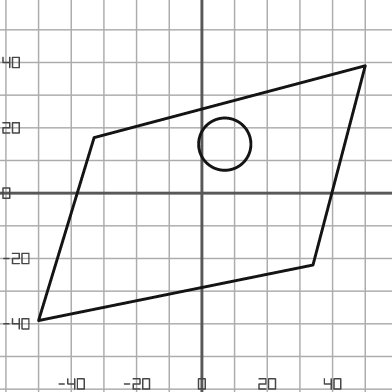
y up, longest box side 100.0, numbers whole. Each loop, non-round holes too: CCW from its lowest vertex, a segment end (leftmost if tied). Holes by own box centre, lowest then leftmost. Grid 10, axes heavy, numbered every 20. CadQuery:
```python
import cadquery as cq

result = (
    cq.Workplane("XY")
    .moveTo(-50.0, -39.0)
    .lineTo(34.0, -22.0)
    .lineTo(50.0, 39.0)
    .lineTo(-33.0, 17.0)
    .close()
    .moveTo(7.0, 15.0)
    .circle(8.0)
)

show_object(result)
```